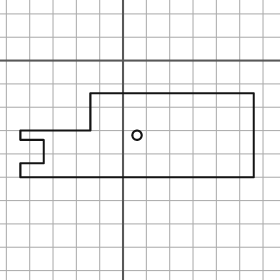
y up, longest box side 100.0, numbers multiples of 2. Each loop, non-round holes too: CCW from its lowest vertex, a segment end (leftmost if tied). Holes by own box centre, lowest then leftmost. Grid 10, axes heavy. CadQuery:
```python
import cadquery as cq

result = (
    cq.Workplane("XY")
    .moveTo(-44.0, -50.0)
    .lineTo(56.0, -50.0)
    .lineTo(56.0, -14.0)
    .lineTo(-14.0, -14.0)
    .lineTo(-14.0, -30.0)
    .lineTo(-44.0, -30.0)
    .lineTo(-44.0, -34.0)
    .lineTo(-34.0, -34.0)
    .lineTo(-34.0, -44.0)
    .lineTo(-44.0, -44.0)
    .close()
    .moveTo(6.0, -32.0)
    .circle(2.0)
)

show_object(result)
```